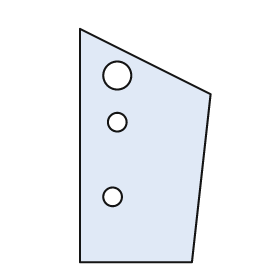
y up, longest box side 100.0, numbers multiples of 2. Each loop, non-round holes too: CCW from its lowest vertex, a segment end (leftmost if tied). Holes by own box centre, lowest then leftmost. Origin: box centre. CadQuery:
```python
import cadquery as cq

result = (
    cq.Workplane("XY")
    .moveTo(-28.0, -50.0)
    .lineTo(20.0, -50.0)
    .lineTo(28.0, 22.0)
    .lineTo(-28.0, 50.0)
    .close()
    .moveTo(-14.0, -22.0)
    .circle(4.0)
    .moveTo(-12.0, 10.0)
    .circle(4.0)
    .moveTo(-12.0, 30.0)
    .circle(6.0)
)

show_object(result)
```